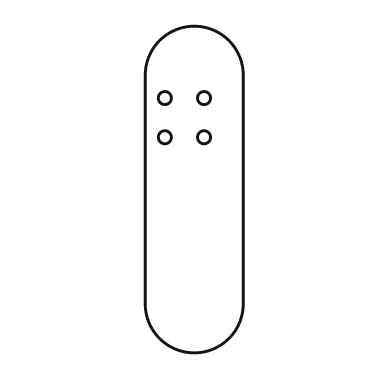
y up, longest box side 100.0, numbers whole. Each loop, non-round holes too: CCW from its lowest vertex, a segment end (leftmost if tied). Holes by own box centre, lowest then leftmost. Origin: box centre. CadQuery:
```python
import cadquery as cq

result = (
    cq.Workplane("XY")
    .moveTo(-15.0, -35.0)
    .threePointArc((0.0, -50.0), (15.0, -35.0))
    .lineTo(15.0, 35.0)
    .threePointArc((0.0, 50.0), (-15.0, 35.0))
    .close()
    .moveTo(-9.0, 16.0)
    .circle(2.0)
    .moveTo(3.0, 16.0)
    .circle(2.0)
    .moveTo(-9.0, 28.0)
    .circle(2.0)
    .moveTo(3.0, 28.0)
    .circle(2.0)
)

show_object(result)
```